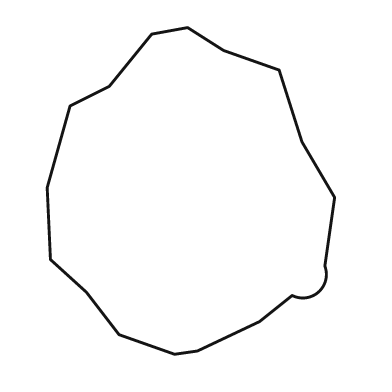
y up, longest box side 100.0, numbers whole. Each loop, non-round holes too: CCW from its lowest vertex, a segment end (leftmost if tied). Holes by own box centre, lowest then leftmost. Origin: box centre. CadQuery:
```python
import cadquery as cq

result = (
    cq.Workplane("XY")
    .moveTo(-5.0, -50.0)
    .lineTo(2.0, -49.0)
    .lineTo(21.0, -40.0)
    .lineTo(31.0, -32.0)
    .threePointArc((39.0, -31.0), (41.0, -23.0))
    .lineTo(44.0, -2.0)
    .lineTo(34.0, 15.0)
    .lineTo(27.0, 37.0)
    .lineTo(10.0, 43.0)
    .lineTo(-1.0, 50.0)
    .lineTo(-12.0, 48.0)
    .lineTo(-25.0, 32.0)
    .lineTo(-37.0, 26.0)
    .lineTo(-44.0, 1.0)
    .lineTo(-43.0, -21.0)
    .lineTo(-32.0, -31.0)
    .lineTo(-22.0, -44.0)
    .close()
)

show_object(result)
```